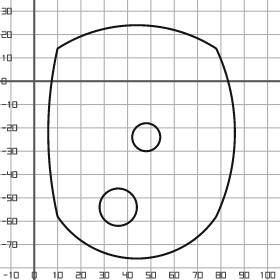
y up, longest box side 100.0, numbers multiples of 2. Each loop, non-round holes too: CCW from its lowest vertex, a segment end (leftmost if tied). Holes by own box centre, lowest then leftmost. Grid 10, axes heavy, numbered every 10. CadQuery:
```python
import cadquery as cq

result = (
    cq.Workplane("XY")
    .moveTo(10.0, -58.0)
    .threePointArc((44.0, -76.0), (78.0, -58.0))
    .threePointArc((86.0, -22.0), (78.0, 14.0))
    .threePointArc((44.0, 24.0), (10.0, 14.0))
    .threePointArc((6.0, -22.0), (10.0, -58.0))
    .close()
    .moveTo(36.0, -54.0)
    .circle(8.0)
    .moveTo(48.0, -24.0)
    .circle(6.0)
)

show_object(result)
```